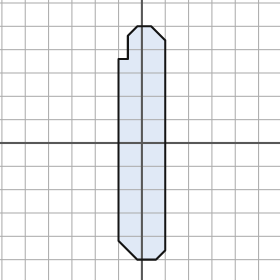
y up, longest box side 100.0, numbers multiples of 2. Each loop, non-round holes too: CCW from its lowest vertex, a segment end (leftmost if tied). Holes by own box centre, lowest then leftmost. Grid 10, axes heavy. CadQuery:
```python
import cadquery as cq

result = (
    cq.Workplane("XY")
    .moveTo(-2.0, -50.0)
    .lineTo(6.0, -50.0)
    .lineTo(10.0, -46.0)
    .lineTo(10.0, 44.0)
    .lineTo(4.0, 50.0)
    .lineTo(-2.0, 50.0)
    .lineTo(-6.0, 46.0)
    .lineTo(-6.0, 36.0)
    .lineTo(-10.0, 36.0)
    .lineTo(-10.0, -42.0)
    .close()
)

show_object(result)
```